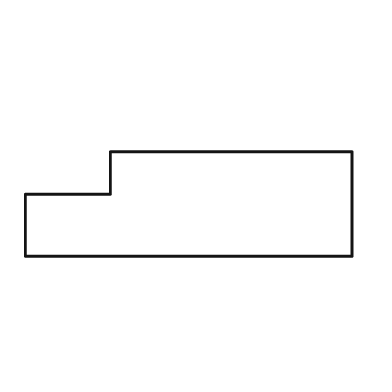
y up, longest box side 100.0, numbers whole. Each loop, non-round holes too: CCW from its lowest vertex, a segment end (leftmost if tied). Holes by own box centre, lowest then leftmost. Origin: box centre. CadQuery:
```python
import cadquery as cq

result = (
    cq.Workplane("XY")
    .moveTo(-50.0, -16.0)
    .lineTo(50.0, -16.0)
    .lineTo(50.0, 16.0)
    .lineTo(-24.0, 16.0)
    .lineTo(-24.0, 3.0)
    .lineTo(-50.0, 3.0)
    .close()
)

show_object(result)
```